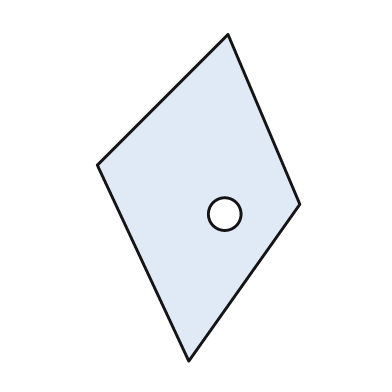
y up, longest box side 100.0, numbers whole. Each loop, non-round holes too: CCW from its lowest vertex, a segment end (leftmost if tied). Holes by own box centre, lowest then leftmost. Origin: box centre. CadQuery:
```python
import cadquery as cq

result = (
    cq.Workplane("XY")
    .moveTo(-3.0, -50.0)
    .lineTo(31.0, -2.0)
    .lineTo(9.0, 50.0)
    .lineTo(-31.0, 10.0)
    .close()
    .moveTo(8.0, -5.0)
    .circle(5.0)
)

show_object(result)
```